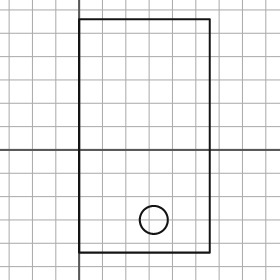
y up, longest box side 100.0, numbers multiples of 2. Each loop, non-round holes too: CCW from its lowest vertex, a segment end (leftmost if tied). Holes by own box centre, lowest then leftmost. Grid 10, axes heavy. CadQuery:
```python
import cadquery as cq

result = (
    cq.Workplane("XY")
    .moveTo(0.0, -44.0)
    .lineTo(56.0, -44.0)
    .lineTo(56.0, 56.0)
    .lineTo(0.0, 56.0)
    .close()
    .moveTo(32.0, -30.0)
    .circle(6.0)
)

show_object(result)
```